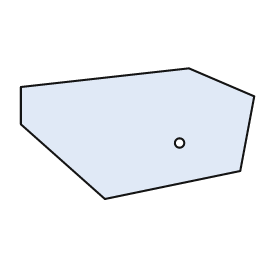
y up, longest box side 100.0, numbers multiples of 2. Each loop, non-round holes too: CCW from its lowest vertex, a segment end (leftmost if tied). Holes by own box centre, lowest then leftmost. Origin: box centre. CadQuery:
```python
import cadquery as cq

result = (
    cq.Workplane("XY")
    .moveTo(-14.0, -28.0)
    .lineTo(44.0, -16.0)
    .lineTo(50.0, 16.0)
    .lineTo(22.0, 28.0)
    .lineTo(-50.0, 20.0)
    .lineTo(-50.0, 4.0)
    .close()
    .moveTo(18.0, -4.0)
    .circle(2.0)
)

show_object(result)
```